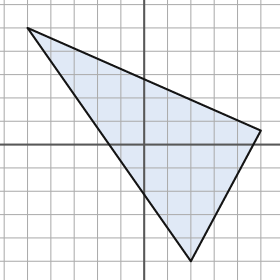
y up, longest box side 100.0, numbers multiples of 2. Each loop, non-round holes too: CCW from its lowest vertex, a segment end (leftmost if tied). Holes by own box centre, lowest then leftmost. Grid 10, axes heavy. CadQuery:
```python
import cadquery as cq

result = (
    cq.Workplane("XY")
    .moveTo(20.0, -50.0)
    .lineTo(50.0, 6.0)
    .lineTo(-50.0, 50.0)
    .close()
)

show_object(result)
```